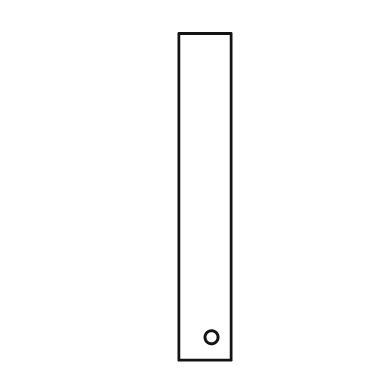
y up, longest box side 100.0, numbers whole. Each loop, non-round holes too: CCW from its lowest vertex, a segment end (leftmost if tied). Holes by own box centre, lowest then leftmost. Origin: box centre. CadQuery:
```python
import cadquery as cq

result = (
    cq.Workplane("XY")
    .moveTo(-8.0, -50.0)
    .lineTo(8.0, -50.0)
    .lineTo(8.0, 50.0)
    .lineTo(-8.0, 50.0)
    .close()
    .moveTo(2.0, -43.0)
    .circle(2.0)
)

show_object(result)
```